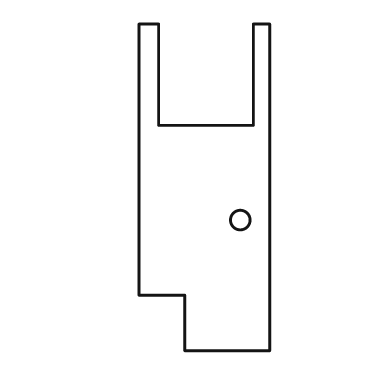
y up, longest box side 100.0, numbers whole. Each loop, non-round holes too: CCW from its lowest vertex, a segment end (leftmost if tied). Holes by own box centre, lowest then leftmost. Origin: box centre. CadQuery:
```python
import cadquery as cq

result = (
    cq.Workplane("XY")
    .moveTo(-6.0, -50.0)
    .lineTo(20.0, -50.0)
    .lineTo(20.0, 50.0)
    .lineTo(15.0, 50.0)
    .lineTo(15.0, 19.0)
    .lineTo(-14.0, 19.0)
    .lineTo(-14.0, 50.0)
    .lineTo(-20.0, 50.0)
    .lineTo(-20.0, -33.0)
    .lineTo(-6.0, -33.0)
    .close()
    .moveTo(11.0, -10.0)
    .circle(3.0)
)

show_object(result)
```